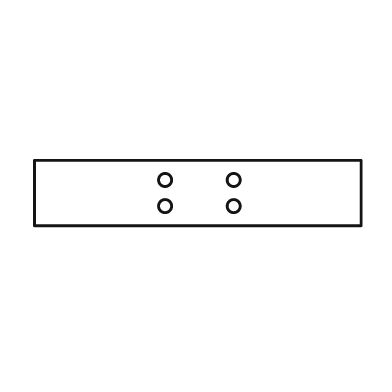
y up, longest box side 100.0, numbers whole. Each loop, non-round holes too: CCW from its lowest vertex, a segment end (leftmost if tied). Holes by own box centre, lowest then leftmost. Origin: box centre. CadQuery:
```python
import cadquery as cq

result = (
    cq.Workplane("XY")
    .moveTo(-50.0, -10.0)
    .lineTo(50.0, -10.0)
    .lineTo(50.0, 10.0)
    .lineTo(-50.0, 10.0)
    .close()
    .moveTo(-10.0, -4.0)
    .circle(2.0)
    .moveTo(11.0, -4.0)
    .circle(2.0)
    .moveTo(-10.0, 4.0)
    .circle(2.0)
    .moveTo(11.0, 4.0)
    .circle(2.0)
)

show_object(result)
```